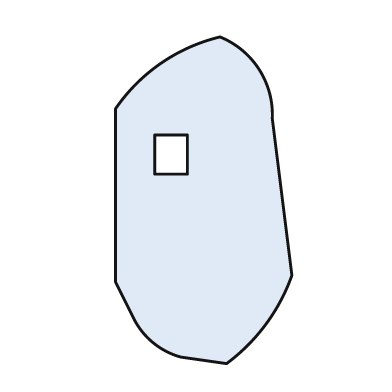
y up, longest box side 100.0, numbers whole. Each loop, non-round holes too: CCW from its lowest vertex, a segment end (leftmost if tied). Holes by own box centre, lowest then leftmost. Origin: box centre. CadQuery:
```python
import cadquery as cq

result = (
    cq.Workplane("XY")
    .moveTo(7.0, -50.0)
    .threePointArc((19.0, -38.0), (27.0, -23.0))
    .lineTo(21.0, 25.0)
    .threePointArc((17.0, 40.0), (5.0, 50.0))
    .threePointArc((-13.0, 42.0), (-27.0, 28.0))
    .lineTo(-27.0, -25.0)
    .lineTo(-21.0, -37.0)
    .threePointArc((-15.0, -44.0), (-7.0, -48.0))
    .close()
    .moveTo(-15.0, 8.0)
    .lineTo(-5.0, 8.0)
    .lineTo(-5.0, 20.0)
    .lineTo(-15.0, 20.0)
    .close()
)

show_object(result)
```